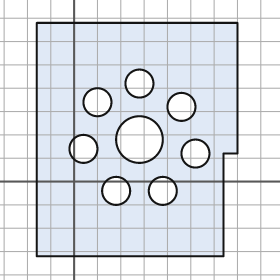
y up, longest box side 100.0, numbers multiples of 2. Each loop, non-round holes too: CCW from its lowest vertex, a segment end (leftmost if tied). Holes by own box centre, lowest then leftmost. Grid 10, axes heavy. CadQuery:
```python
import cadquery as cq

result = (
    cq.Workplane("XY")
    .moveTo(-16.0, -32.0)
    .lineTo(64.0, -32.0)
    .lineTo(64.0, 12.0)
    .lineTo(70.0, 12.0)
    .lineTo(70.0, 68.0)
    .lineTo(-16.0, 68.0)
    .close()
    .moveTo(18.0, -4.0)
    .circle(6.0)
    .moveTo(38.0, -4.0)
    .circle(6.0)
    .moveTo(52.0, 12.0)
    .circle(6.0)
    .moveTo(4.0, 14.0)
    .circle(6.0)
    .moveTo(28.0, 18.0)
    .circle(10.0)
    .moveTo(46.0, 32.0)
    .circle(6.0)
    .moveTo(10.0, 34.0)
    .circle(6.0)
    .moveTo(28.0, 42.0)
    .circle(6.0)
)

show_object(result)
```